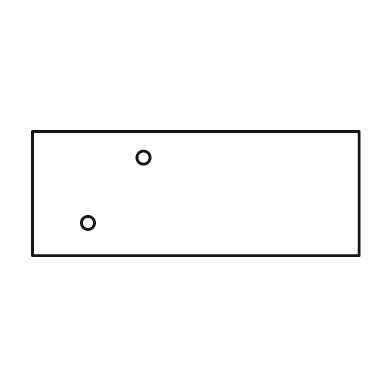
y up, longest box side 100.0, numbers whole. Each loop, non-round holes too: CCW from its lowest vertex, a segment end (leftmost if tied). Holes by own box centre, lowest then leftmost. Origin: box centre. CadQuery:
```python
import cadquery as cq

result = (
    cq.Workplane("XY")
    .moveTo(-50.0, -19.0)
    .lineTo(50.0, -19.0)
    .lineTo(50.0, 19.0)
    .lineTo(-50.0, 19.0)
    .close()
    .moveTo(-33.0, -9.0)
    .circle(2.0)
    .moveTo(-16.0, 11.0)
    .circle(2.0)
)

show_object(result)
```